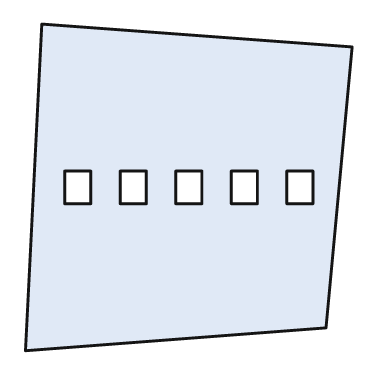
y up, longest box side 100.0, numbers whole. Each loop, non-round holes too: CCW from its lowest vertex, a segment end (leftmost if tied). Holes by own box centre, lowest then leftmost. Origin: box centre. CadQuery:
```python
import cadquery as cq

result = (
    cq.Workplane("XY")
    .moveTo(-50.0, -50.0)
    .lineTo(42.0, -43.0)
    .lineTo(50.0, 43.0)
    .lineTo(-45.0, 50.0)
    .close()
    .moveTo(-38.0, -5.0)
    .lineTo(-30.0, -5.0)
    .lineTo(-30.0, 5.0)
    .lineTo(-38.0, 5.0)
    .close()
    .moveTo(-21.0, -5.0)
    .lineTo(-13.0, -5.0)
    .lineTo(-13.0, 5.0)
    .lineTo(-21.0, 5.0)
    .close()
    .moveTo(-4.0, -5.0)
    .lineTo(4.0, -5.0)
    .lineTo(4.0, 5.0)
    .lineTo(-4.0, 5.0)
    .close()
    .moveTo(13.0, -5.0)
    .lineTo(21.0, -5.0)
    .lineTo(21.0, 5.0)
    .lineTo(13.0, 5.0)
    .close()
    .moveTo(30.0, -5.0)
    .lineTo(38.0, -5.0)
    .lineTo(38.0, 5.0)
    .lineTo(30.0, 5.0)
    .close()
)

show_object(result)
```